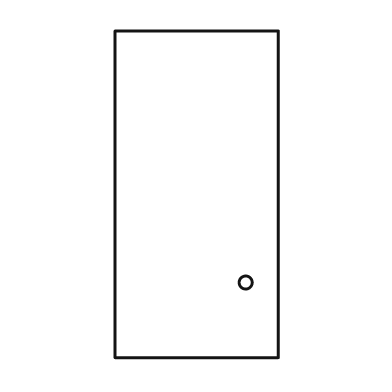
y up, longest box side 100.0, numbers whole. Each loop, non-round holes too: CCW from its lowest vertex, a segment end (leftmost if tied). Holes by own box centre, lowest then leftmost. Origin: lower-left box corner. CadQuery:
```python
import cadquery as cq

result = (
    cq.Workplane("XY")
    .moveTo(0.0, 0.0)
    .lineTo(50.0, 0.0)
    .lineTo(50.0, 100.0)
    .lineTo(0.0, 100.0)
    .close()
    .moveTo(40.0, 23.0)
    .circle(2.0)
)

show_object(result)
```